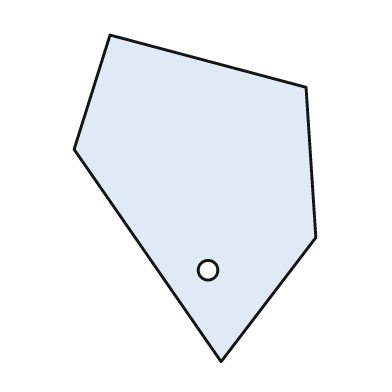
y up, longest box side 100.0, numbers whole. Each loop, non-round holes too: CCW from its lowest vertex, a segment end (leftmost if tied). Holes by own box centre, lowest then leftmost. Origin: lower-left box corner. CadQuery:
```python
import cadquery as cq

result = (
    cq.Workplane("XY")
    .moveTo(45.0, 0.0)
    .lineTo(74.0, 38.0)
    .lineTo(71.0, 84.0)
    .lineTo(11.0, 100.0)
    .lineTo(0.0, 65.0)
    .close()
    .moveTo(41.0, 28.0)
    .circle(3.0)
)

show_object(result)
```